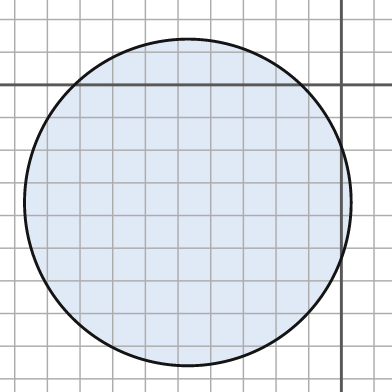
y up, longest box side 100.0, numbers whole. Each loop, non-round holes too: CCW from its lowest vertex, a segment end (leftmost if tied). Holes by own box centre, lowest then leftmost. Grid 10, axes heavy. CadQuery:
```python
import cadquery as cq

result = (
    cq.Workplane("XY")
    .moveTo(-47.0, -36.0)
    .circle(50.0)
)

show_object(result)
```